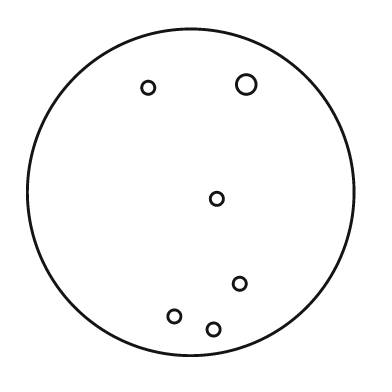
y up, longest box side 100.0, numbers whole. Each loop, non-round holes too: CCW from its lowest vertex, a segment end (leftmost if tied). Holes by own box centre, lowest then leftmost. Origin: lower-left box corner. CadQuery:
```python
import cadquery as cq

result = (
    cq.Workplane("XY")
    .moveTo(50.0, 50.0)
    .circle(50.0)
    .moveTo(57.0, 8.0)
    .circle(2.0)
    .moveTo(45.0, 12.0)
    .circle(2.0)
    .moveTo(65.0, 22.0)
    .circle(2.0)
    .moveTo(58.0, 48.0)
    .circle(2.0)
    .moveTo(37.0, 82.0)
    .circle(2.0)
    .moveTo(67.0, 83.0)
    .circle(3.0)
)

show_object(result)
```